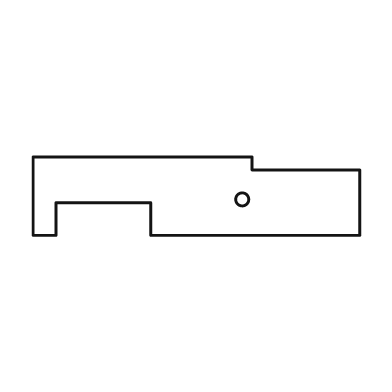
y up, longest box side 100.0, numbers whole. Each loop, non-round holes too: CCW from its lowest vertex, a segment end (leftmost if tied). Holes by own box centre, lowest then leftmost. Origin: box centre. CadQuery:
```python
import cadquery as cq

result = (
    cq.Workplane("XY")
    .moveTo(-50.0, -12.0)
    .lineTo(-43.0, -12.0)
    .lineTo(-43.0, -2.0)
    .lineTo(-14.0, -2.0)
    .lineTo(-14.0, -12.0)
    .lineTo(50.0, -12.0)
    .lineTo(50.0, 8.0)
    .lineTo(17.0, 8.0)
    .lineTo(17.0, 12.0)
    .lineTo(-50.0, 12.0)
    .close()
    .moveTo(14.0, -1.0)
    .circle(2.0)
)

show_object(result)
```